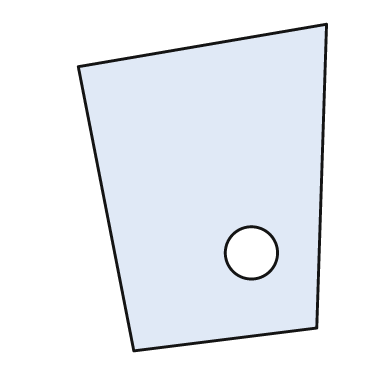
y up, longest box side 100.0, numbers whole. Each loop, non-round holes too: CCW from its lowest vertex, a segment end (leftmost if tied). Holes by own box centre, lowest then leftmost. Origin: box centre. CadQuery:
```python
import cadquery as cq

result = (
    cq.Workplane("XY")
    .moveTo(-21.0, -50.0)
    .lineTo(35.0, -43.0)
    .lineTo(38.0, 50.0)
    .lineTo(-38.0, 37.0)
    .close()
    .moveTo(15.0, -20.0)
    .circle(8.0)
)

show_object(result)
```